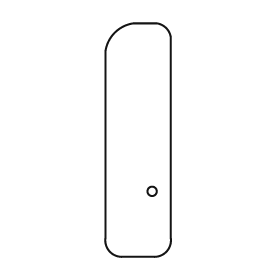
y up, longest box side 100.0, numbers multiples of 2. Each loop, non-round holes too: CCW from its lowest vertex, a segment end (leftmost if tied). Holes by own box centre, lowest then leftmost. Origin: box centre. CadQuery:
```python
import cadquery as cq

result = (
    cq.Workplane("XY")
    .moveTo(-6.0, -50.0)
    .lineTo(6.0, -50.0)
    .threePointArc((12.0, -48.0), (14.0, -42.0))
    .lineTo(14.0, 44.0)
    .threePointArc((12.0, 48.0), (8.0, 50.0))
    .lineTo(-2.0, 50.0)
    .threePointArc((-10.0, 46.0), (-14.0, 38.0))
    .lineTo(-14.0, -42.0)
    .threePointArc((-12.0, -48.0), (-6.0, -50.0))
    .close()
    .moveTo(6.0, -22.0)
    .circle(2.0)
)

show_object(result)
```